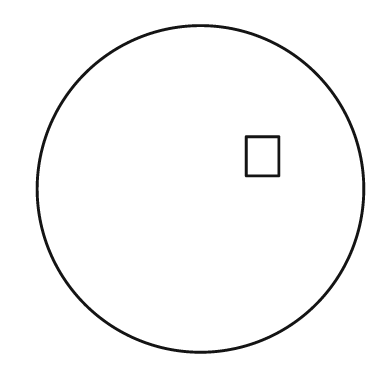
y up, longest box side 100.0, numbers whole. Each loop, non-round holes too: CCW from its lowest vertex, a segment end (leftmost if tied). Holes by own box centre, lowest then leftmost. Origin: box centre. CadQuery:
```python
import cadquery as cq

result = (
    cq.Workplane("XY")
    .moveTo(0.0, 0.0)
    .circle(50.0)
    .moveTo(14.0, 4.0)
    .lineTo(24.0, 4.0)
    .lineTo(24.0, 16.0)
    .lineTo(14.0, 16.0)
    .close()
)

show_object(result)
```